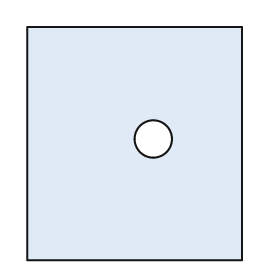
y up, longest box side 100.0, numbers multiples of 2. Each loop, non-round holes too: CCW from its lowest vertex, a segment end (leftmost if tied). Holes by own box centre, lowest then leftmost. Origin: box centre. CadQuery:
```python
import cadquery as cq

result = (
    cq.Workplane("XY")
    .moveTo(-46.0, -50.0)
    .lineTo(46.0, -50.0)
    .lineTo(46.0, 50.0)
    .lineTo(-46.0, 50.0)
    .close()
    .moveTo(8.0, 2.0)
    .circle(8.0)
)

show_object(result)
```